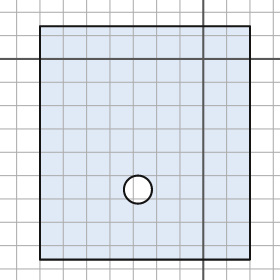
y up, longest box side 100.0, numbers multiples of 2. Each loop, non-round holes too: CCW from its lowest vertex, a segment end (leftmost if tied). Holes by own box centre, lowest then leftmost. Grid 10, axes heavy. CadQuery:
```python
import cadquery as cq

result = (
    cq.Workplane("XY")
    .moveTo(-70.0, -86.0)
    .lineTo(20.0, -86.0)
    .lineTo(20.0, 14.0)
    .lineTo(-70.0, 14.0)
    .close()
    .moveTo(-28.0, -56.0)
    .circle(6.0)
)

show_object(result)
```